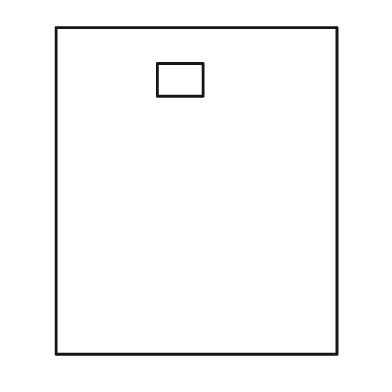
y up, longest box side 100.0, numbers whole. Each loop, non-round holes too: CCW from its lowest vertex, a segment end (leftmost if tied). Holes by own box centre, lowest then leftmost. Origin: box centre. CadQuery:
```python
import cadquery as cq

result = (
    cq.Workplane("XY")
    .moveTo(-43.0, -50.0)
    .lineTo(43.0, -50.0)
    .lineTo(43.0, 50.0)
    .lineTo(-43.0, 50.0)
    .close()
    .moveTo(-12.0, 29.0)
    .lineTo(2.0, 29.0)
    .lineTo(2.0, 39.0)
    .lineTo(-12.0, 39.0)
    .close()
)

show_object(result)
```